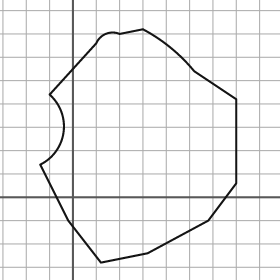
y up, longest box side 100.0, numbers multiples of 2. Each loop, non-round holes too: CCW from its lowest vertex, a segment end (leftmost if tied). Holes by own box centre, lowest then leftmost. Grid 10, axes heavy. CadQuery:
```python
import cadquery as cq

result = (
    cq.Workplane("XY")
    .moveTo(12.0, -28.0)
    .lineTo(32.0, -24.0)
    .lineTo(58.0, -10.0)
    .lineTo(70.0, 6.0)
    .lineTo(70.0, 42.0)
    .lineTo(52.0, 54.0)
    .threePointArc((42.0, 64.0), (30.0, 72.0))
    .lineTo(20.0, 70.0)
    .threePointArc((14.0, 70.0), (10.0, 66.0))
    .lineTo(-10.0, 44.0)
    .threePointArc((-4.0, 28.0), (-14.0, 14.0))
    .lineTo(-2.0, -10.0)
    .close()
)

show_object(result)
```